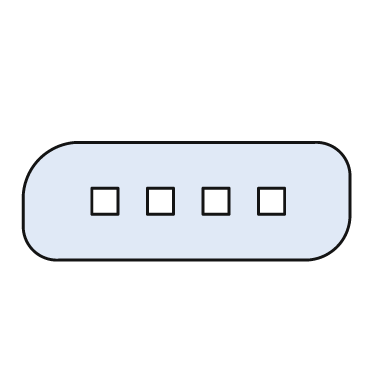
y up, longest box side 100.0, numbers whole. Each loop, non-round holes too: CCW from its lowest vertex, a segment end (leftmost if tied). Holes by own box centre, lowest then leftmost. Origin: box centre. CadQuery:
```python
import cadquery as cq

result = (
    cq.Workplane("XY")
    .moveTo(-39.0, -18.0)
    .lineTo(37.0, -18.0)
    .threePointArc((46.0, -14.0), (50.0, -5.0))
    .lineTo(50.0, 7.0)
    .threePointArc((47.0, 15.0), (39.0, 18.0))
    .lineTo(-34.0, 18.0)
    .threePointArc((-45.0, 13.0), (-50.0, 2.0))
    .lineTo(-50.0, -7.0)
    .threePointArc((-47.0, -15.0), (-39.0, -18.0))
    .close()
    .moveTo(-29.0, -4.0)
    .lineTo(-21.0, -4.0)
    .lineTo(-21.0, 4.0)
    .lineTo(-29.0, 4.0)
    .close()
    .moveTo(-12.0, -4.0)
    .lineTo(-4.0, -4.0)
    .lineTo(-4.0, 4.0)
    .lineTo(-12.0, 4.0)
    .close()
    .moveTo(5.0, -4.0)
    .lineTo(13.0, -4.0)
    .lineTo(13.0, 4.0)
    .lineTo(5.0, 4.0)
    .close()
    .moveTo(22.0, -4.0)
    .lineTo(30.0, -4.0)
    .lineTo(30.0, 4.0)
    .lineTo(22.0, 4.0)
    .close()
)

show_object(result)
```